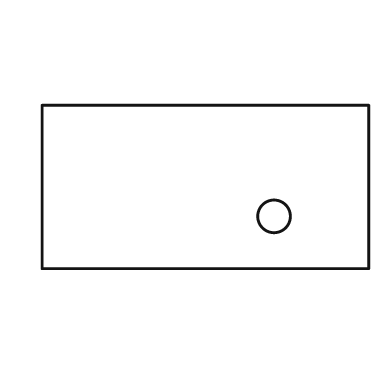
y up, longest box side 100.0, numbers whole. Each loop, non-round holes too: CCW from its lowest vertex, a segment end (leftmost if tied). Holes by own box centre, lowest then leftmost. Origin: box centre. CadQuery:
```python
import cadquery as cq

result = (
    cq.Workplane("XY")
    .moveTo(-50.0, -25.0)
    .lineTo(50.0, -25.0)
    .lineTo(50.0, 25.0)
    .lineTo(-50.0, 25.0)
    .close()
    .moveTo(21.0, -9.0)
    .circle(5.0)
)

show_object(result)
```